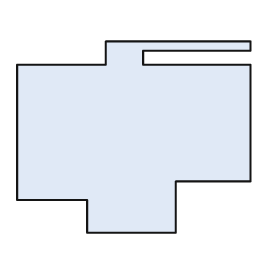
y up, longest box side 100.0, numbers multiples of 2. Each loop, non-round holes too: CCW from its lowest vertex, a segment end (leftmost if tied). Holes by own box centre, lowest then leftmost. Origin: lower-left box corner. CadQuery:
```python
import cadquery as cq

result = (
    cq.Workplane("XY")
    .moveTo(30.0, 0.0)
    .lineTo(68.0, 0.0)
    .lineTo(68.0, 22.0)
    .lineTo(100.0, 22.0)
    .lineTo(100.0, 72.0)
    .lineTo(54.0, 72.0)
    .lineTo(54.0, 78.0)
    .lineTo(100.0, 78.0)
    .lineTo(100.0, 82.0)
    .lineTo(38.0, 82.0)
    .lineTo(38.0, 72.0)
    .lineTo(0.0, 72.0)
    .lineTo(0.0, 14.0)
    .lineTo(30.0, 14.0)
    .close()
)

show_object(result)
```